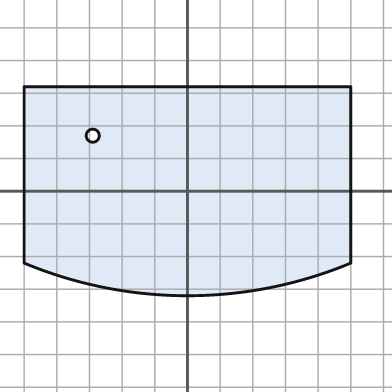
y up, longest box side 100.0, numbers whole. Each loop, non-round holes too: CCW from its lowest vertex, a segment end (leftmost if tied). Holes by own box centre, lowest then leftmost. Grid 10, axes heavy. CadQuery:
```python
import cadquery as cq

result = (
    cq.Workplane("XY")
    .moveTo(-50.0, -22.0)
    .threePointArc((0.0, -32.0), (50.0, -22.0))
    .lineTo(50.0, 32.0)
    .lineTo(-50.0, 32.0)
    .close()
    .moveTo(-29.0, 17.0)
    .circle(2.0)
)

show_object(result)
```